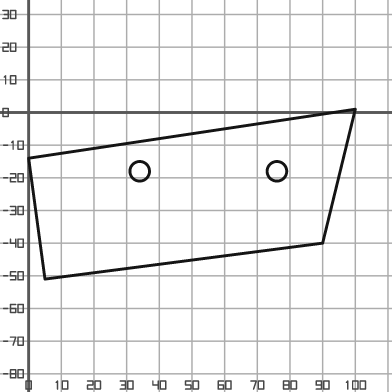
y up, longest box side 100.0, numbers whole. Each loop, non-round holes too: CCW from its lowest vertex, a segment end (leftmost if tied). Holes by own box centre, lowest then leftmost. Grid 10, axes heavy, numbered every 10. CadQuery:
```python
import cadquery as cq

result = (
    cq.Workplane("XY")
    .moveTo(5.0, -51.0)
    .lineTo(90.0, -40.0)
    .lineTo(100.0, 1.0)
    .lineTo(0.0, -14.0)
    .close()
    .moveTo(34.0, -18.0)
    .circle(3.0)
    .moveTo(76.0, -18.0)
    .circle(3.0)
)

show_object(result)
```